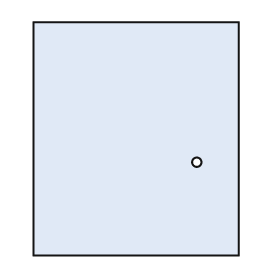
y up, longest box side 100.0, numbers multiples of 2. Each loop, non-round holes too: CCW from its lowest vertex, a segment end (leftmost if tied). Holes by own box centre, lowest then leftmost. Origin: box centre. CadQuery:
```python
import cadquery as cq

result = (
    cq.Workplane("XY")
    .moveTo(-44.0, -50.0)
    .lineTo(44.0, -50.0)
    .lineTo(44.0, 50.0)
    .lineTo(-44.0, 50.0)
    .close()
    .moveTo(26.0, -10.0)
    .circle(2.0)
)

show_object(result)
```